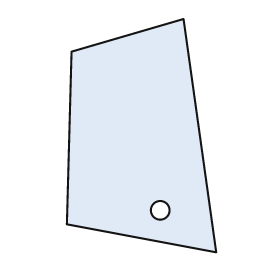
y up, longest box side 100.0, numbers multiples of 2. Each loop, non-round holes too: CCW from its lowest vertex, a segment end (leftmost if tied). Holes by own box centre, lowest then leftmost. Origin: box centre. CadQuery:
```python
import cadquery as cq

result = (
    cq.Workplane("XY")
    .moveTo(32.0, -50.0)
    .lineTo(18.0, 50.0)
    .lineTo(-30.0, 36.0)
    .lineTo(-32.0, -38.0)
    .close()
    .moveTo(8.0, -32.0)
    .circle(4.0)
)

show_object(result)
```